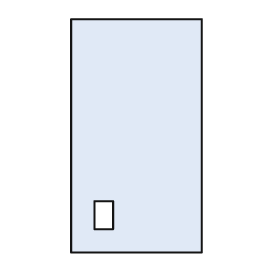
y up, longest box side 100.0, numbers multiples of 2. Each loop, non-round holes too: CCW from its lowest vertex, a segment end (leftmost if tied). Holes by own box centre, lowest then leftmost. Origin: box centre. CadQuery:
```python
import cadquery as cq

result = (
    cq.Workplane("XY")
    .moveTo(-28.0, -50.0)
    .lineTo(28.0, -50.0)
    .lineTo(28.0, 50.0)
    .lineTo(-28.0, 50.0)
    .close()
    .moveTo(-18.0, -40.0)
    .lineTo(-10.0, -40.0)
    .lineTo(-10.0, -28.0)
    .lineTo(-18.0, -28.0)
    .close()
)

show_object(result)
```